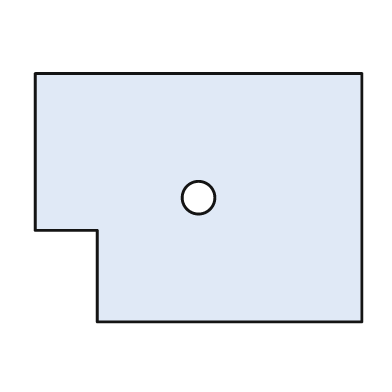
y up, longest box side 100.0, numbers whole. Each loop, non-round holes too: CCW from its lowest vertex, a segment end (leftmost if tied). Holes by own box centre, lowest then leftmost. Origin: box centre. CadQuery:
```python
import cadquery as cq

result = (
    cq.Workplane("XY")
    .moveTo(-31.0, -38.0)
    .lineTo(50.0, -38.0)
    .lineTo(50.0, 38.0)
    .lineTo(-50.0, 38.0)
    .lineTo(-50.0, -10.0)
    .lineTo(-31.0, -10.0)
    .close()
    .moveTo(0.0, 0.0)
    .circle(5.0)
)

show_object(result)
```